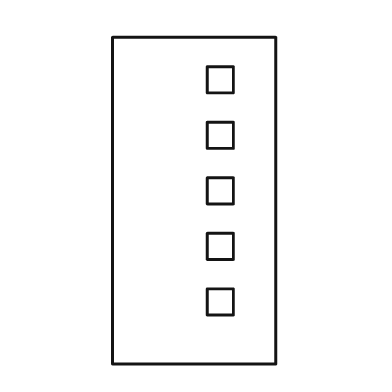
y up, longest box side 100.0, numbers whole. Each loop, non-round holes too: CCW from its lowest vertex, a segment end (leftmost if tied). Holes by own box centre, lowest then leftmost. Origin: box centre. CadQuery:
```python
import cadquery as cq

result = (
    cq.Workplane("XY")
    .moveTo(-25.0, -50.0)
    .lineTo(25.0, -50.0)
    .lineTo(25.0, 50.0)
    .lineTo(-25.0, 50.0)
    .close()
    .moveTo(4.0, -35.0)
    .lineTo(12.0, -35.0)
    .lineTo(12.0, -27.0)
    .lineTo(4.0, -27.0)
    .close()
    .moveTo(4.0, -18.0)
    .lineTo(12.0, -18.0)
    .lineTo(12.0, -10.0)
    .lineTo(4.0, -10.0)
    .close()
    .moveTo(4.0, -1.0)
    .lineTo(12.0, -1.0)
    .lineTo(12.0, 7.0)
    .lineTo(4.0, 7.0)
    .close()
    .moveTo(4.0, 16.0)
    .lineTo(12.0, 16.0)
    .lineTo(12.0, 24.0)
    .lineTo(4.0, 24.0)
    .close()
    .moveTo(4.0, 33.0)
    .lineTo(12.0, 33.0)
    .lineTo(12.0, 41.0)
    .lineTo(4.0, 41.0)
    .close()
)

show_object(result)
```